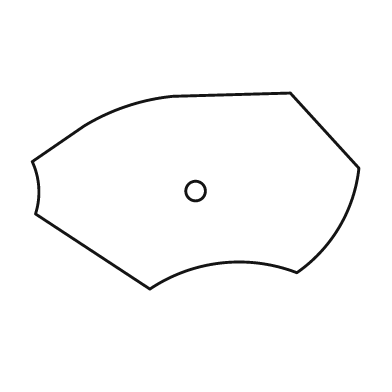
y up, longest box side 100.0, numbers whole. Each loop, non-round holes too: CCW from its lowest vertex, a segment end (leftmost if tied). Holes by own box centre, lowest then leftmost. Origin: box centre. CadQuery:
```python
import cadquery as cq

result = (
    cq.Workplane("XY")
    .moveTo(-14.0, -30.0)
    .threePointArc((8.0, -22.0), (31.0, -25.0))
    .threePointArc((44.0, -11.0), (50.0, 7.0))
    .lineTo(29.0, 30.0)
    .lineTo(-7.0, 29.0)
    .threePointArc((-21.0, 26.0), (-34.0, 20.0))
    .lineTo(-50.0, 9.0)
    .threePointArc((-48.0, 1.0), (-49.0, -7.0))
    .close()
    .moveTo(0.0, 0.0)
    .circle(3.0)
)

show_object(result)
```